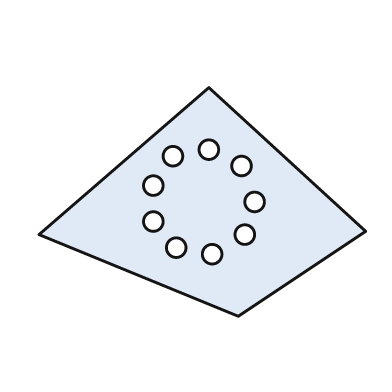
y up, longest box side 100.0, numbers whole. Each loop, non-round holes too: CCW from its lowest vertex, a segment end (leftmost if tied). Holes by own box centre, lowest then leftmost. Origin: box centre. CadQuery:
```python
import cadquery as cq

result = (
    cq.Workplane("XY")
    .moveTo(11.0, -35.0)
    .lineTo(50.0, -9.0)
    .lineTo(2.0, 35.0)
    .lineTo(-50.0, -10.0)
    .close()
    .moveTo(3.0, -16.0)
    .circle(3.0)
    .moveTo(-8.0, -14.0)
    .circle(3.0)
    .moveTo(13.0, -10.0)
    .circle(3.0)
    .moveTo(-15.0, -6.0)
    .circle(3.0)
    .moveTo(16.0, 0.0)
    .circle(3.0)
    .moveTo(-15.0, 5.0)
    .circle(3.0)
    .moveTo(12.0, 11.0)
    .circle(3.0)
    .moveTo(-9.0, 14.0)
    .circle(3.0)
    .moveTo(2.0, 16.0)
    .circle(3.0)
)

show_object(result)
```